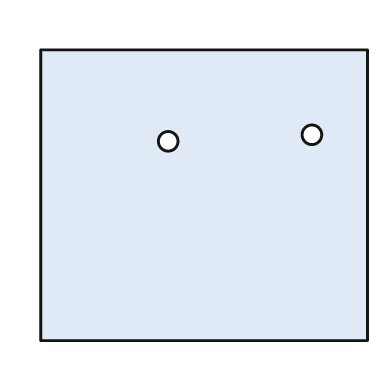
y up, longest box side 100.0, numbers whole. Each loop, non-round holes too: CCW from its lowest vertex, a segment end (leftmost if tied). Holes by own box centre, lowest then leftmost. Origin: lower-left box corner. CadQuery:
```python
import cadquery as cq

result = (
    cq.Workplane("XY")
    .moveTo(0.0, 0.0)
    .lineTo(100.0, 0.0)
    .lineTo(100.0, 89.0)
    .lineTo(0.0, 89.0)
    .close()
    .moveTo(39.0, 61.0)
    .circle(3.0)
    .moveTo(83.0, 63.0)
    .circle(3.0)
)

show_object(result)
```